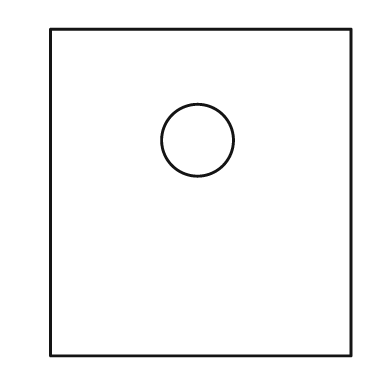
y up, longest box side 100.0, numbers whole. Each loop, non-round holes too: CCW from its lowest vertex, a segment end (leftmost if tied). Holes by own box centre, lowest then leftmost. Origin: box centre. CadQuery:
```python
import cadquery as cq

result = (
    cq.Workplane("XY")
    .moveTo(-46.0, -50.0)
    .lineTo(46.0, -50.0)
    .lineTo(46.0, 50.0)
    .lineTo(-46.0, 50.0)
    .close()
    .moveTo(-1.0, 16.0)
    .circle(11.0)
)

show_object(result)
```